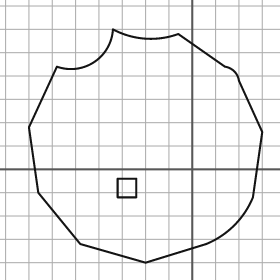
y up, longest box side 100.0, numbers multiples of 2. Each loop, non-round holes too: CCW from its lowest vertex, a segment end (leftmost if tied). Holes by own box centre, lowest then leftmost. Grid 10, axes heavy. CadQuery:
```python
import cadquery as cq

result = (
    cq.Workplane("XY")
    .moveTo(-20.0, -40.0)
    .lineTo(6.0, -32.0)
    .threePointArc((18.0, -24.0), (26.0, -12.0))
    .lineTo(30.0, 16.0)
    .lineTo(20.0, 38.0)
    .threePointArc((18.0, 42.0), (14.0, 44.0))
    .lineTo(-6.0, 58.0)
    .threePointArc((-20.0, 56.0), (-34.0, 60.0))
    .threePointArc((-42.0, 46.0), (-58.0, 44.0))
    .lineTo(-70.0, 18.0)
    .lineTo(-66.0, -10.0)
    .lineTo(-48.0, -32.0)
    .close()
    .moveTo(-32.0, -12.0)
    .lineTo(-24.0, -12.0)
    .lineTo(-24.0, -4.0)
    .lineTo(-32.0, -4.0)
    .close()
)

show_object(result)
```